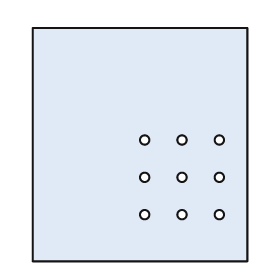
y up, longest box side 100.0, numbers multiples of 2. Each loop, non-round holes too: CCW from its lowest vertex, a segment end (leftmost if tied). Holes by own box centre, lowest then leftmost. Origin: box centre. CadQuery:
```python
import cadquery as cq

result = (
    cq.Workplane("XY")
    .moveTo(-46.0, -50.0)
    .lineTo(46.0, -50.0)
    .lineTo(46.0, 50.0)
    .lineTo(-46.0, 50.0)
    .close()
    .moveTo(2.0, -30.0)
    .circle(2.0)
    .moveTo(18.0, -30.0)
    .circle(2.0)
    .moveTo(34.0, -30.0)
    .circle(2.0)
    .moveTo(2.0, -14.0)
    .circle(2.0)
    .moveTo(18.0, -14.0)
    .circle(2.0)
    .moveTo(34.0, -14.0)
    .circle(2.0)
    .moveTo(2.0, 2.0)
    .circle(2.0)
    .moveTo(18.0, 2.0)
    .circle(2.0)
    .moveTo(34.0, 2.0)
    .circle(2.0)
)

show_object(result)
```